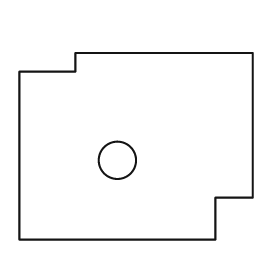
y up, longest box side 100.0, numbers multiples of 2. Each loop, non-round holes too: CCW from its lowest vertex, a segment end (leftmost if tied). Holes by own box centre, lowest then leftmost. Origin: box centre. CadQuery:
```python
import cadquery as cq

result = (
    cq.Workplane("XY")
    .moveTo(-50.0, -40.0)
    .lineTo(34.0, -40.0)
    .lineTo(34.0, -22.0)
    .lineTo(50.0, -22.0)
    .lineTo(50.0, 40.0)
    .lineTo(-26.0, 40.0)
    .lineTo(-26.0, 32.0)
    .lineTo(-50.0, 32.0)
    .close()
    .moveTo(-8.0, -6.0)
    .circle(8.0)
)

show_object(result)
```